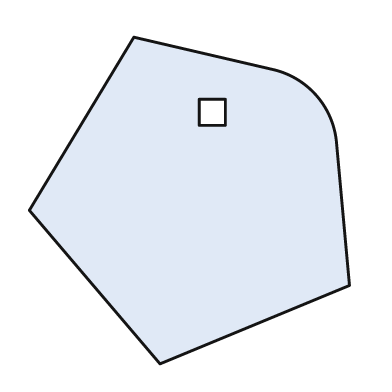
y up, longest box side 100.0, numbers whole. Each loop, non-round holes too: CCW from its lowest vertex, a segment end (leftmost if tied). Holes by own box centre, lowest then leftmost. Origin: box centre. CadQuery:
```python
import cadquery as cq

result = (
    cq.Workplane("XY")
    .moveTo(-9.0, -50.0)
    .lineTo(49.0, -26.0)
    .lineTo(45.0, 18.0)
    .threePointArc((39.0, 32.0), (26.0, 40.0))
    .lineTo(-17.0, 50.0)
    .lineTo(-49.0, -3.0)
    .close()
    .moveTo(3.0, 23.0)
    .lineTo(11.0, 23.0)
    .lineTo(11.0, 31.0)
    .lineTo(3.0, 31.0)
    .close()
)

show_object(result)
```